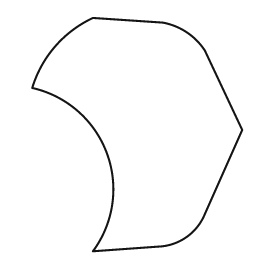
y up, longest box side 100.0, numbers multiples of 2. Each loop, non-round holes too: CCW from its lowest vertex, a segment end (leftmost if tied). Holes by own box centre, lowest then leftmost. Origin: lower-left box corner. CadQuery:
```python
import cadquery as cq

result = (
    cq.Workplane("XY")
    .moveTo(26.0, 0.0)
    .lineTo(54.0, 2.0)
    .threePointArc((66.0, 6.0), (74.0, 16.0))
    .lineTo(90.0, 52.0)
    .lineTo(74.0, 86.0)
    .threePointArc((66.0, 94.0), (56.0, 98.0))
    .lineTo(26.0, 100.0)
    .threePointArc((10.0, 88.0), (0.0, 70.0))
    .threePointArc((32.0, 42.0), (26.0, 0.0))
    .close()
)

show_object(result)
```